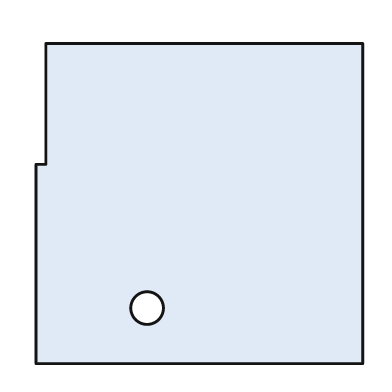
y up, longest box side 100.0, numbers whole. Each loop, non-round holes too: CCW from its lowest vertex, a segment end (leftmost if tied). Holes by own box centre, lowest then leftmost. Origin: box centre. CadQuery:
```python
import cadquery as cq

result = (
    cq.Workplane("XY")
    .moveTo(-50.0, -49.0)
    .lineTo(50.0, -49.0)
    .lineTo(50.0, 49.0)
    .lineTo(-47.0, 49.0)
    .lineTo(-47.0, 12.0)
    .lineTo(-50.0, 12.0)
    .close()
    .moveTo(-16.0, -32.0)
    .circle(5.0)
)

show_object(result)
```